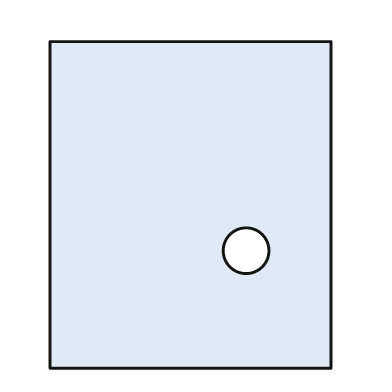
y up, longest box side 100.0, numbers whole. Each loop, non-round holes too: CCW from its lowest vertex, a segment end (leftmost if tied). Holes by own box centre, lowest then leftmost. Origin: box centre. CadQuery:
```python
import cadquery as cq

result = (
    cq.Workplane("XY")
    .moveTo(-43.0, -50.0)
    .lineTo(43.0, -50.0)
    .lineTo(43.0, 50.0)
    .lineTo(-43.0, 50.0)
    .close()
    .moveTo(17.0, -14.0)
    .circle(7.0)
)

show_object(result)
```